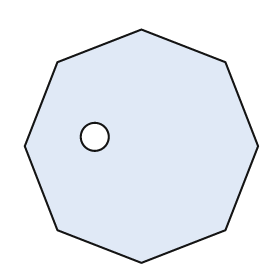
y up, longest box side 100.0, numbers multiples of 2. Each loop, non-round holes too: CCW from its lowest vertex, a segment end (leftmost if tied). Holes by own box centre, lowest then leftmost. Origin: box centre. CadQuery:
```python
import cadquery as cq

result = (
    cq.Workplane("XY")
    .moveTo(0.0, -50.0)
    .lineTo(36.0, -36.0)
    .lineTo(50.0, 0.0)
    .lineTo(36.0, 36.0)
    .lineTo(0.0, 50.0)
    .lineTo(-36.0, 36.0)
    .lineTo(-50.0, 0.0)
    .lineTo(-36.0, -36.0)
    .close()
    .moveTo(-20.0, 4.0)
    .circle(6.0)
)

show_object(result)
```